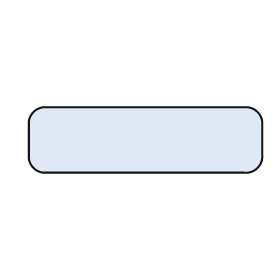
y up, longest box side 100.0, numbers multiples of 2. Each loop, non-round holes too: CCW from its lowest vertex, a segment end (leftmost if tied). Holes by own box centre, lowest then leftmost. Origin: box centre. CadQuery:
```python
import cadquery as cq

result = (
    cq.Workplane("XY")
    .moveTo(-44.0, -14.0)
    .lineTo(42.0, -14.0)
    .threePointArc((48.0, -12.0), (50.0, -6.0))
    .lineTo(50.0, 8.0)
    .threePointArc((48.0, 12.0), (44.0, 14.0))
    .lineTo(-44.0, 14.0)
    .threePointArc((-48.0, 12.0), (-50.0, 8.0))
    .lineTo(-50.0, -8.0)
    .threePointArc((-48.0, -12.0), (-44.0, -14.0))
    .close()
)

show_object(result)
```